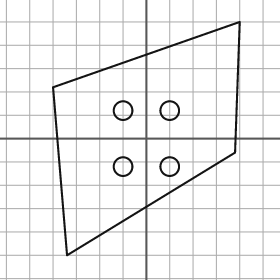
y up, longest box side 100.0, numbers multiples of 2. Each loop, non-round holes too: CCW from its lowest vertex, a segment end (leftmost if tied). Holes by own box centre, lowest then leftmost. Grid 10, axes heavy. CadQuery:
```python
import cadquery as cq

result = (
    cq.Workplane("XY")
    .moveTo(-34.0, -50.0)
    .lineTo(38.0, -6.0)
    .lineTo(40.0, 50.0)
    .lineTo(-40.0, 22.0)
    .close()
    .moveTo(-10.0, -12.0)
    .circle(4.0)
    .moveTo(10.0, -12.0)
    .circle(4.0)
    .moveTo(-10.0, 12.0)
    .circle(4.0)
    .moveTo(10.0, 12.0)
    .circle(4.0)
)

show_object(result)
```